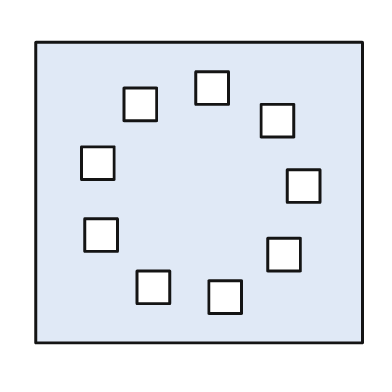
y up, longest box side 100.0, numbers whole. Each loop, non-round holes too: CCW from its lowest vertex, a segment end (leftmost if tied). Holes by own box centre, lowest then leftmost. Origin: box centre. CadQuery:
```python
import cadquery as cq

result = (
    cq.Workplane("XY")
    .moveTo(-50.0, -46.0)
    .lineTo(50.0, -46.0)
    .lineTo(50.0, 46.0)
    .lineTo(-50.0, 46.0)
    .close()
    .moveTo(3.0, -37.0)
    .lineTo(13.0, -37.0)
    .lineTo(13.0, -27.0)
    .lineTo(3.0, -27.0)
    .close()
    .moveTo(-19.0, -34.0)
    .lineTo(-9.0, -34.0)
    .lineTo(-9.0, -24.0)
    .lineTo(-19.0, -24.0)
    .close()
    .moveTo(21.0, -24.0)
    .lineTo(31.0, -24.0)
    .lineTo(31.0, -14.0)
    .lineTo(21.0, -14.0)
    .close()
    .moveTo(-35.0, -18.0)
    .lineTo(-25.0, -18.0)
    .lineTo(-25.0, -8.0)
    .lineTo(-35.0, -8.0)
    .close()
    .moveTo(27.0, -3.0)
    .lineTo(37.0, -3.0)
    .lineTo(37.0, 7.0)
    .lineTo(27.0, 7.0)
    .close()
    .moveTo(-36.0, 4.0)
    .lineTo(-26.0, 4.0)
    .lineTo(-26.0, 14.0)
    .lineTo(-36.0, 14.0)
    .close()
    .moveTo(19.0, 17.0)
    .lineTo(29.0, 17.0)
    .lineTo(29.0, 27.0)
    .lineTo(19.0, 27.0)
    .close()
    .moveTo(-23.0, 22.0)
    .lineTo(-13.0, 22.0)
    .lineTo(-13.0, 32.0)
    .lineTo(-23.0, 32.0)
    .close()
    .moveTo(-1.0, 27.0)
    .lineTo(9.0, 27.0)
    .lineTo(9.0, 37.0)
    .lineTo(-1.0, 37.0)
    .close()
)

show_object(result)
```